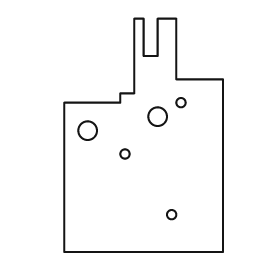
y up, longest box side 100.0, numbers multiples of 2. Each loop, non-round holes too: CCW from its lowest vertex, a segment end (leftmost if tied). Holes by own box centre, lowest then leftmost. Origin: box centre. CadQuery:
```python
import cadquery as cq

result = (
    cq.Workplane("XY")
    .moveTo(-34.0, -50.0)
    .lineTo(34.0, -50.0)
    .lineTo(34.0, 24.0)
    .lineTo(14.0, 24.0)
    .lineTo(14.0, 50.0)
    .lineTo(6.0, 50.0)
    .lineTo(6.0, 34.0)
    .lineTo(0.0, 34.0)
    .lineTo(0.0, 50.0)
    .lineTo(-4.0, 50.0)
    .lineTo(-4.0, 18.0)
    .lineTo(-10.0, 18.0)
    .lineTo(-10.0, 14.0)
    .lineTo(-34.0, 14.0)
    .close()
    .moveTo(12.0, -34.0)
    .circle(2.0)
    .moveTo(-8.0, -8.0)
    .circle(2.0)
    .moveTo(-24.0, 2.0)
    .circle(4.0)
    .moveTo(6.0, 8.0)
    .circle(4.0)
    .moveTo(16.0, 14.0)
    .circle(2.0)
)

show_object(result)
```